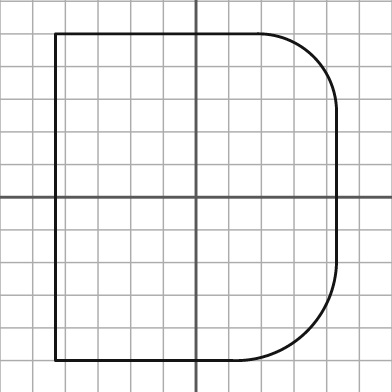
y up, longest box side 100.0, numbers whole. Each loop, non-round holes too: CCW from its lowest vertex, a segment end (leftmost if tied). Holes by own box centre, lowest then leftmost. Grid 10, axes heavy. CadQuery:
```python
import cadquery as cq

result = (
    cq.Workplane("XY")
    .moveTo(-43.0, -50.0)
    .lineTo(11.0, -50.0)
    .threePointArc((34.0, -41.0), (43.0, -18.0))
    .lineTo(43.0, 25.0)
    .threePointArc((36.0, 43.0), (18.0, 50.0))
    .lineTo(-43.0, 50.0)
    .close()
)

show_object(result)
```